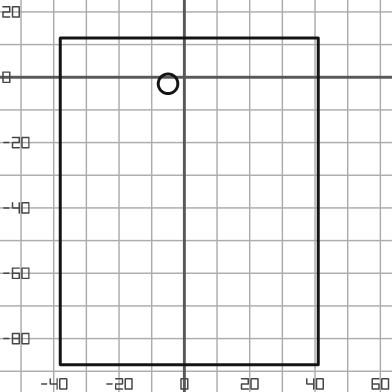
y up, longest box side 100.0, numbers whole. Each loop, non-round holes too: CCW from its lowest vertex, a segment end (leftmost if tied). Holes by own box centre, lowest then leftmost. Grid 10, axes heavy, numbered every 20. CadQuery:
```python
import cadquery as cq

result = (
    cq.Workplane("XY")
    .moveTo(-38.0, -88.0)
    .lineTo(41.0, -88.0)
    .lineTo(41.0, 12.0)
    .lineTo(-38.0, 12.0)
    .close()
    .moveTo(-5.0, -2.0)
    .circle(3.0)
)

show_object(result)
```